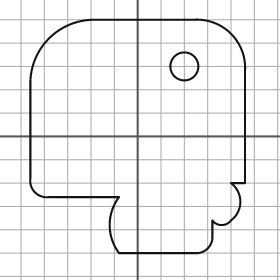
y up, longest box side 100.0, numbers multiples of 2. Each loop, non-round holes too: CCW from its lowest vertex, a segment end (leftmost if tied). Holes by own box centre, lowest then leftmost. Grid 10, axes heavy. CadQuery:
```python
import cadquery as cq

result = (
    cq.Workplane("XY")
    .moveTo(-8.0, -50.0)
    .lineTo(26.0, -50.0)
    .threePointArc((30.0, -48.0), (32.0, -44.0))
    .lineTo(32.0, -36.0)
    .threePointArc((36.0, -38.0), (40.0, -36.0))
    .threePointArc((44.0, -28.0), (40.0, -20.0))
    .lineTo(46.0, -20.0)
    .lineTo(46.0, 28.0)
    .threePointArc((40.0, 44.0), (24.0, 50.0))
    .lineTo(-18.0, 50.0)
    .threePointArc((-38.0, 42.0), (-46.0, 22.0))
    .lineTo(-46.0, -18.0)
    .threePointArc((-44.0, -24.0), (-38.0, -26.0))
    .lineTo(-8.0, -26.0)
    .threePointArc((-12.0, -38.0), (-8.0, -50.0))
    .close()
    .moveTo(20.0, 30.0)
    .circle(6.0)
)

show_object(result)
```